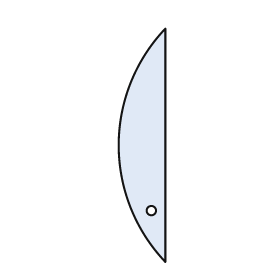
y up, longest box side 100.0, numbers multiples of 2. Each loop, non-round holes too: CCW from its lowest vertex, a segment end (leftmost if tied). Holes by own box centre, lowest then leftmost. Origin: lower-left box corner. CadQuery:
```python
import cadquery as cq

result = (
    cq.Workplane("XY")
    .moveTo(20.0, 0.0)
    .lineTo(20.0, 100.0)
    .threePointArc((0.0, 50.0), (20.0, 0.0))
    .close()
    .moveTo(14.0, 22.0)
    .circle(2.0)
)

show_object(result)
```